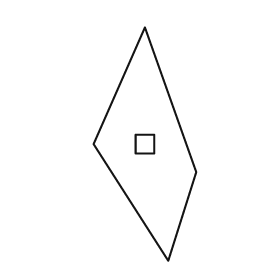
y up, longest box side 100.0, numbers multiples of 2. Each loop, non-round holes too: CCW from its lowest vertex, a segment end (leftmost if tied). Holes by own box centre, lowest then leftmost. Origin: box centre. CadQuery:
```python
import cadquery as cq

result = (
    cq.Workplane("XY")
    .moveTo(10.0, -50.0)
    .lineTo(22.0, -12.0)
    .lineTo(0.0, 50.0)
    .lineTo(-22.0, 0.0)
    .close()
    .moveTo(-4.0, -4.0)
    .lineTo(4.0, -4.0)
    .lineTo(4.0, 4.0)
    .lineTo(-4.0, 4.0)
    .close()
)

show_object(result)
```